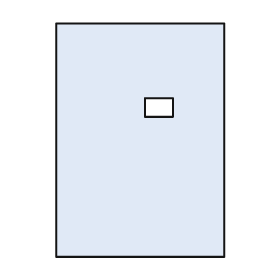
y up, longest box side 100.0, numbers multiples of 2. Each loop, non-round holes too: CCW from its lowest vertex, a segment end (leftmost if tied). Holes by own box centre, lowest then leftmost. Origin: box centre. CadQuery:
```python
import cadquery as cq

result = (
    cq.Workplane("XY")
    .moveTo(-36.0, -50.0)
    .lineTo(36.0, -50.0)
    .lineTo(36.0, 50.0)
    .lineTo(-36.0, 50.0)
    .close()
    .moveTo(2.0, 10.0)
    .lineTo(14.0, 10.0)
    .lineTo(14.0, 18.0)
    .lineTo(2.0, 18.0)
    .close()
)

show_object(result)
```